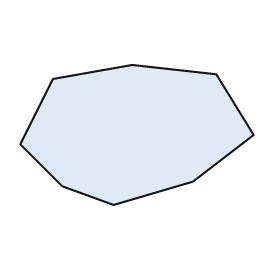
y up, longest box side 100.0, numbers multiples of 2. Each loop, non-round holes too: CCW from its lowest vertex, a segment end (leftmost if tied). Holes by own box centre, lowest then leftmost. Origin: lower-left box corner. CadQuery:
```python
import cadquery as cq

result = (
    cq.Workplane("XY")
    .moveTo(40.0, 0.0)
    .lineTo(74.0, 10.0)
    .lineTo(100.0, 30.0)
    .lineTo(84.0, 56.0)
    .lineTo(48.0, 60.0)
    .lineTo(14.0, 54.0)
    .lineTo(0.0, 26.0)
    .lineTo(18.0, 8.0)
    .close()
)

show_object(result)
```